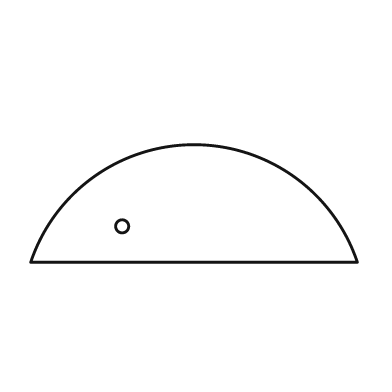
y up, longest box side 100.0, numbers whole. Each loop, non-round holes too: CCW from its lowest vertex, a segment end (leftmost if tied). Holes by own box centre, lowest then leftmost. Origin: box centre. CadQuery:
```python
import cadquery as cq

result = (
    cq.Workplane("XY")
    .moveTo(-50.0, -18.0)
    .lineTo(50.0, -18.0)
    .threePointArc((0.0, 18.0), (-50.0, -18.0))
    .close()
    .moveTo(-22.0, -7.0)
    .circle(2.0)
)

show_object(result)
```